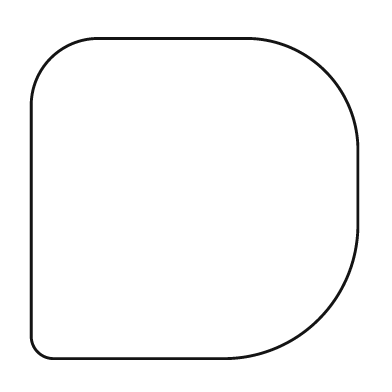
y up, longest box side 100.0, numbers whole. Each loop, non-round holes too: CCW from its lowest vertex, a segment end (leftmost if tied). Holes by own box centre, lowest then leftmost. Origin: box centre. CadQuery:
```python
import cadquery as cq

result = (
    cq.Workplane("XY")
    .moveTo(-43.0, -49.0)
    .lineTo(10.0, -49.0)
    .threePointArc((38.0, -37.0), (50.0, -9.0))
    .lineTo(50.0, 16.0)
    .threePointArc((40.0, 39.0), (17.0, 49.0))
    .lineTo(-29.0, 49.0)
    .threePointArc((-44.0, 43.0), (-50.0, 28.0))
    .lineTo(-50.0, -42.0)
    .threePointArc((-48.0, -47.0), (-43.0, -49.0))
    .close()
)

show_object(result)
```